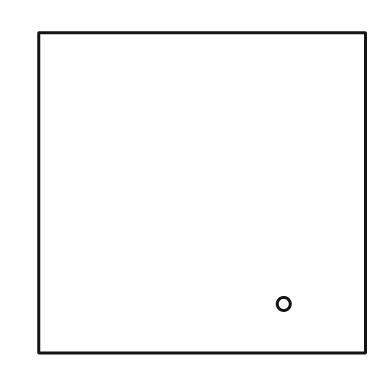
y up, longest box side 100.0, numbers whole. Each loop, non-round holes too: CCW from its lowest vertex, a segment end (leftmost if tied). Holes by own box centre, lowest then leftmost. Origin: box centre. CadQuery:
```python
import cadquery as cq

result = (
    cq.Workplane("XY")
    .moveTo(-50.0, -49.0)
    .lineTo(50.0, -49.0)
    .lineTo(50.0, 49.0)
    .lineTo(-50.0, 49.0)
    .close()
    .moveTo(25.0, -34.0)
    .circle(2.0)
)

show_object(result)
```